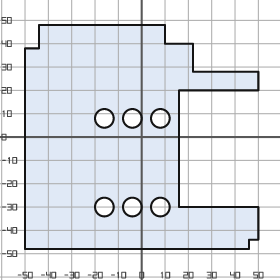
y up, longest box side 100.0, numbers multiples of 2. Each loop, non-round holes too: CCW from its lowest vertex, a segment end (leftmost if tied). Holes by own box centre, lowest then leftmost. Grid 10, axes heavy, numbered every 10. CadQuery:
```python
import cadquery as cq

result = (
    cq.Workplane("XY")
    .moveTo(-50.0, -48.0)
    .lineTo(46.0, -48.0)
    .lineTo(46.0, -44.0)
    .lineTo(50.0, -44.0)
    .lineTo(50.0, -30.0)
    .lineTo(16.0, -30.0)
    .lineTo(16.0, 20.0)
    .lineTo(50.0, 20.0)
    .lineTo(50.0, 28.0)
    .lineTo(22.0, 28.0)
    .lineTo(22.0, 40.0)
    .lineTo(10.0, 40.0)
    .lineTo(10.0, 48.0)
    .lineTo(-44.0, 48.0)
    .lineTo(-44.0, 38.0)
    .lineTo(-50.0, 38.0)
    .close()
    .moveTo(-16.0, -30.0)
    .circle(4.0)
    .moveTo(-4.0, -30.0)
    .circle(4.0)
    .moveTo(8.0, -30.0)
    .circle(4.0)
    .moveTo(-16.0, 8.0)
    .circle(4.0)
    .moveTo(-4.0, 8.0)
    .circle(4.0)
    .moveTo(8.0, 8.0)
    .circle(4.0)
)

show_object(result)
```